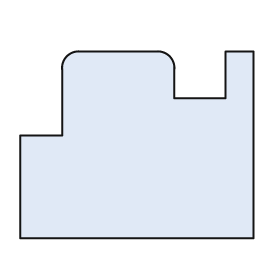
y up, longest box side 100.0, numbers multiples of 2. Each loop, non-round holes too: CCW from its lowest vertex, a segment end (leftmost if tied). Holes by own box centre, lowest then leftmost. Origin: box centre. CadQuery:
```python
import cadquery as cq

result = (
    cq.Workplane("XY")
    .moveTo(-50.0, -40.0)
    .lineTo(50.0, -40.0)
    .lineTo(50.0, 40.0)
    .lineTo(38.0, 40.0)
    .lineTo(38.0, 20.0)
    .lineTo(16.0, 20.0)
    .lineTo(16.0, 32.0)
    .threePointArc((14.0, 38.0), (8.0, 40.0))
    .lineTo(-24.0, 40.0)
    .threePointArc((-30.0, 38.0), (-32.0, 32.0))
    .lineTo(-32.0, 4.0)
    .lineTo(-50.0, 4.0)
    .close()
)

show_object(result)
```